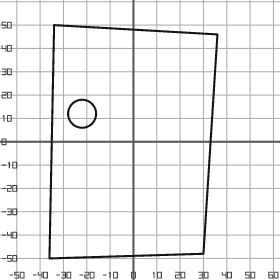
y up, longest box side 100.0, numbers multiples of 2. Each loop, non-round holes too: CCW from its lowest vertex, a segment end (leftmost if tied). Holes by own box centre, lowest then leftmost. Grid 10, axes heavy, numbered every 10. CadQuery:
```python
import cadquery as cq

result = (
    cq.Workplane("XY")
    .moveTo(-36.0, -50.0)
    .lineTo(30.0, -48.0)
    .lineTo(36.0, 46.0)
    .lineTo(-34.0, 50.0)
    .close()
    .moveTo(-22.0, 12.0)
    .circle(6.0)
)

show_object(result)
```